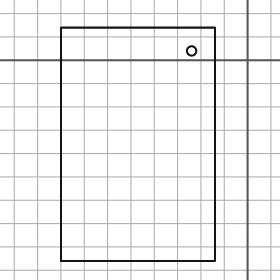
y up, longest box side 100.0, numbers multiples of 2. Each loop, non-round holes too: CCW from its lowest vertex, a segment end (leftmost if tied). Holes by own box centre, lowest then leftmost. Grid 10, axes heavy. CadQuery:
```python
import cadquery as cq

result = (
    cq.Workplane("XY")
    .moveTo(-80.0, -86.0)
    .lineTo(-14.0, -86.0)
    .lineTo(-14.0, 14.0)
    .lineTo(-80.0, 14.0)
    .close()
    .moveTo(-24.0, 4.0)
    .circle(2.0)
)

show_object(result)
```